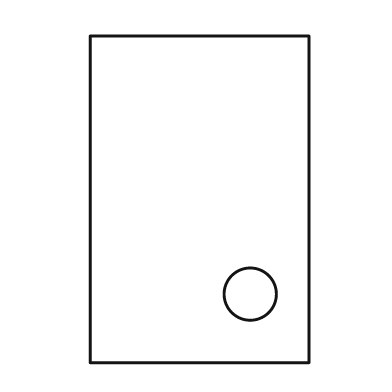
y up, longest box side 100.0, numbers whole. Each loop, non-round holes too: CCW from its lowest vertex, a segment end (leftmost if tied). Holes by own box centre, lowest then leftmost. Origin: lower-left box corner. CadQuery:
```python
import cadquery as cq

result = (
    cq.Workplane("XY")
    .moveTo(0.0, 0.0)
    .lineTo(67.0, 0.0)
    .lineTo(67.0, 100.0)
    .lineTo(0.0, 100.0)
    .close()
    .moveTo(49.0, 21.0)
    .circle(8.0)
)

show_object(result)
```